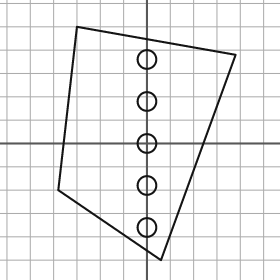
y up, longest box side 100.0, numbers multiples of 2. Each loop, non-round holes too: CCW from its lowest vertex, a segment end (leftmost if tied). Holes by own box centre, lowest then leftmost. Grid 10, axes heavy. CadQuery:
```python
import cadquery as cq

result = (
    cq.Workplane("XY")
    .moveTo(6.0, -50.0)
    .lineTo(38.0, 38.0)
    .lineTo(-30.0, 50.0)
    .lineTo(-38.0, -20.0)
    .close()
    .moveTo(0.0, -36.0)
    .circle(4.0)
    .moveTo(0.0, -18.0)
    .circle(4.0)
    .moveTo(0.0, 0.0)
    .circle(4.0)
    .moveTo(0.0, 18.0)
    .circle(4.0)
    .moveTo(0.0, 36.0)
    .circle(4.0)
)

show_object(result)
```